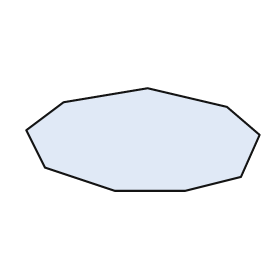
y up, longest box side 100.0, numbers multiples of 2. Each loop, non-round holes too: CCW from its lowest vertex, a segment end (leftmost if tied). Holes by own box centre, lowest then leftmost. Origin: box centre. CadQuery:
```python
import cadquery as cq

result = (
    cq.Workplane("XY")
    .moveTo(-12.0, -22.0)
    .lineTo(18.0, -22.0)
    .lineTo(42.0, -16.0)
    .lineTo(50.0, 2.0)
    .lineTo(36.0, 14.0)
    .lineTo(2.0, 22.0)
    .lineTo(-34.0, 16.0)
    .lineTo(-50.0, 4.0)
    .lineTo(-42.0, -12.0)
    .close()
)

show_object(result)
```